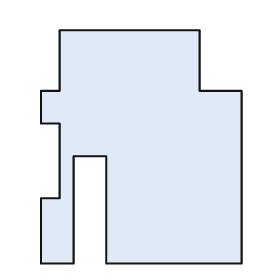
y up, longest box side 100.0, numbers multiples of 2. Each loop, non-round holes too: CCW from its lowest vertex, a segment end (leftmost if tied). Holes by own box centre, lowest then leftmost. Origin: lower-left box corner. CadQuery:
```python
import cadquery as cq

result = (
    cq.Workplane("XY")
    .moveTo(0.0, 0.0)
    .lineTo(14.0, 0.0)
    .lineTo(14.0, 46.0)
    .lineTo(28.0, 46.0)
    .lineTo(28.0, 0.0)
    .lineTo(86.0, 0.0)
    .lineTo(86.0, 74.0)
    .lineTo(68.0, 74.0)
    .lineTo(68.0, 100.0)
    .lineTo(8.0, 100.0)
    .lineTo(8.0, 74.0)
    .lineTo(0.0, 74.0)
    .lineTo(0.0, 60.0)
    .lineTo(8.0, 60.0)
    .lineTo(8.0, 28.0)
    .lineTo(0.0, 28.0)
    .close()
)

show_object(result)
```